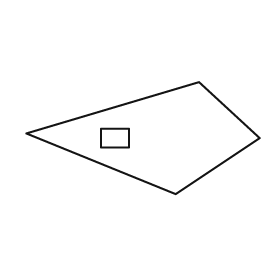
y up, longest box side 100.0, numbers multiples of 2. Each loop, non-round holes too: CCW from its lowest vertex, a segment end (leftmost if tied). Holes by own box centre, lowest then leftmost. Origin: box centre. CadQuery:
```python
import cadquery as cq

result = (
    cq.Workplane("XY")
    .moveTo(14.0, -24.0)
    .lineTo(50.0, 0.0)
    .lineTo(24.0, 24.0)
    .lineTo(-50.0, 2.0)
    .close()
    .moveTo(-18.0, -4.0)
    .lineTo(-6.0, -4.0)
    .lineTo(-6.0, 4.0)
    .lineTo(-18.0, 4.0)
    .close()
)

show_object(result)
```